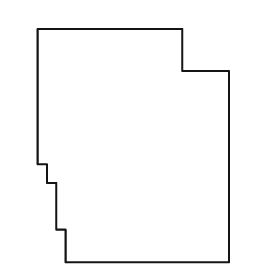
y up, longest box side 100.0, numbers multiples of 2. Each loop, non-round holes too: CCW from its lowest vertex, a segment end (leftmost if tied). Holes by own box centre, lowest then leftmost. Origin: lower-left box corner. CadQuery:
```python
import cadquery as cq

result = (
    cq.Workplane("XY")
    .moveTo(12.0, 0.0)
    .lineTo(82.0, 0.0)
    .lineTo(82.0, 82.0)
    .lineTo(62.0, 82.0)
    .lineTo(62.0, 100.0)
    .lineTo(0.0, 100.0)
    .lineTo(0.0, 42.0)
    .lineTo(4.0, 42.0)
    .lineTo(4.0, 34.0)
    .lineTo(8.0, 34.0)
    .lineTo(8.0, 14.0)
    .lineTo(12.0, 14.0)
    .close()
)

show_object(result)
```